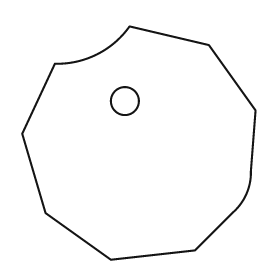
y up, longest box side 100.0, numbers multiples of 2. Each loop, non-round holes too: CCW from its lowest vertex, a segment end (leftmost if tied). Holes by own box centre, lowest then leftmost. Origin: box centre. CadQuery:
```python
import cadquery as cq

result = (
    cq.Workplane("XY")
    .moveTo(-12.0, -50.0)
    .lineTo(24.0, -46.0)
    .lineTo(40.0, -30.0)
    .threePointArc((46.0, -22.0), (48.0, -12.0))
    .lineTo(50.0, 14.0)
    .lineTo(30.0, 42.0)
    .lineTo(-4.0, 50.0)
    .threePointArc((-18.0, 38.0), (-36.0, 34.0))
    .lineTo(-50.0, 4.0)
    .lineTo(-40.0, -30.0)
    .close()
    .moveTo(-6.0, 18.0)
    .circle(6.0)
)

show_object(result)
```